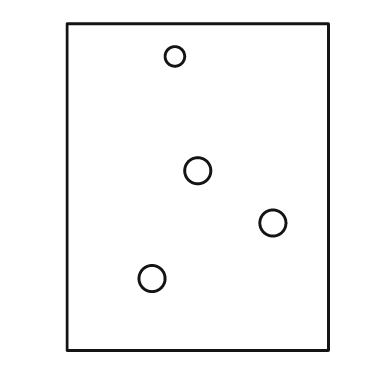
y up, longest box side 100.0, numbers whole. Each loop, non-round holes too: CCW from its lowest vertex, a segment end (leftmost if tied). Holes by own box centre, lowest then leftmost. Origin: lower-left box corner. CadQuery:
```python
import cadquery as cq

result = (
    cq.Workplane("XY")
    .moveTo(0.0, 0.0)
    .lineTo(80.0, 0.0)
    .lineTo(80.0, 100.0)
    .lineTo(0.0, 100.0)
    .close()
    .moveTo(26.0, 22.0)
    .circle(4.0)
    .moveTo(63.0, 39.0)
    .circle(4.0)
    .moveTo(40.0, 55.0)
    .circle(4.0)
    .moveTo(33.0, 90.0)
    .circle(3.0)
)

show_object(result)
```